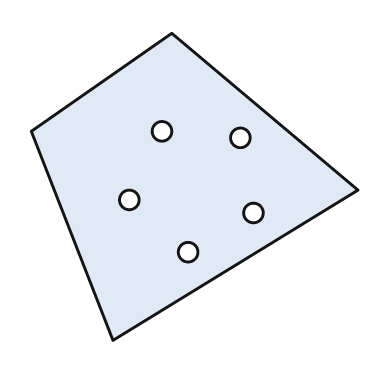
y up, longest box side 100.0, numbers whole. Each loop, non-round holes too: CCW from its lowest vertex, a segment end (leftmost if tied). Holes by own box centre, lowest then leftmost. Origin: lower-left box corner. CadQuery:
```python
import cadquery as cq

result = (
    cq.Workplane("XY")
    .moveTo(25.0, 0.0)
    .lineTo(100.0, 46.0)
    .lineTo(43.0, 94.0)
    .lineTo(0.0, 64.0)
    .close()
    .moveTo(48.0, 27.0)
    .circle(3.0)
    .moveTo(68.0, 39.0)
    .circle(3.0)
    .moveTo(30.0, 43.0)
    .circle(3.0)
    .moveTo(64.0, 62.0)
    .circle(3.0)
    .moveTo(40.0, 64.0)
    .circle(3.0)
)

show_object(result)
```